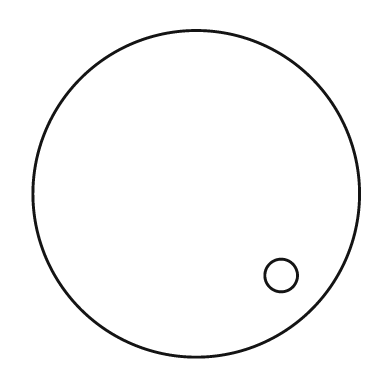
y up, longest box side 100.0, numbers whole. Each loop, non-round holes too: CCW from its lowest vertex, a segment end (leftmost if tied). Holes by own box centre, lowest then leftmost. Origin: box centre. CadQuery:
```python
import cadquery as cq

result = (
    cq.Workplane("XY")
    .moveTo(0.0, 0.0)
    .circle(50.0)
    .moveTo(26.0, -25.0)
    .circle(5.0)
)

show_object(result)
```